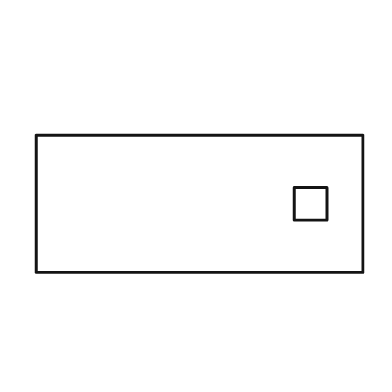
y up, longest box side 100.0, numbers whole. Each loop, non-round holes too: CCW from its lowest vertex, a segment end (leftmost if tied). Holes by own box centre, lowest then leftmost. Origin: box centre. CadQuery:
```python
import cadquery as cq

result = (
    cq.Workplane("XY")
    .moveTo(-50.0, -21.0)
    .lineTo(50.0, -21.0)
    .lineTo(50.0, 21.0)
    .lineTo(-50.0, 21.0)
    .close()
    .moveTo(29.0, -5.0)
    .lineTo(39.0, -5.0)
    .lineTo(39.0, 5.0)
    .lineTo(29.0, 5.0)
    .close()
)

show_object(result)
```